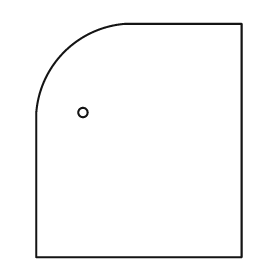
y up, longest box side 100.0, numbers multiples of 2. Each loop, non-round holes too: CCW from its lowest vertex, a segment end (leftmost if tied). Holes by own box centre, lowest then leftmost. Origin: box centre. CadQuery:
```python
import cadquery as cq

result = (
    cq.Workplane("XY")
    .moveTo(-44.0, -50.0)
    .lineTo(44.0, -50.0)
    .lineTo(44.0, 50.0)
    .lineTo(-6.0, 50.0)
    .threePointArc((-32.0, 38.0), (-44.0, 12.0))
    .close()
    .moveTo(-24.0, 12.0)
    .circle(2.0)
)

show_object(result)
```